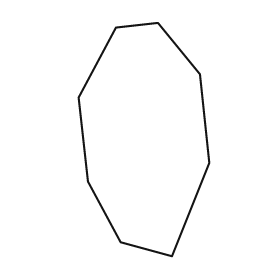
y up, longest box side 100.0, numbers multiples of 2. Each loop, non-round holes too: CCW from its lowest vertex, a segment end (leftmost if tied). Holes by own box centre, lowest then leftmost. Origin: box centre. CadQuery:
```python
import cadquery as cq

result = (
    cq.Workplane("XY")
    .moveTo(12.0, -50.0)
    .lineTo(28.0, -10.0)
    .lineTo(24.0, 28.0)
    .lineTo(6.0, 50.0)
    .lineTo(-12.0, 48.0)
    .lineTo(-28.0, 18.0)
    .lineTo(-24.0, -18.0)
    .lineTo(-10.0, -44.0)
    .close()
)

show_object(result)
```